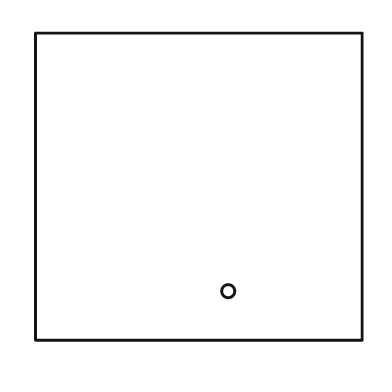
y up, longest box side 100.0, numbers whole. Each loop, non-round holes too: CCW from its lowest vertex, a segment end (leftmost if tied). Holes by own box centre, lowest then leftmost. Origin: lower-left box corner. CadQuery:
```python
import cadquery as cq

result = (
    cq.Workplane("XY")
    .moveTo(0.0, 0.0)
    .lineTo(100.0, 0.0)
    .lineTo(100.0, 94.0)
    .lineTo(0.0, 94.0)
    .close()
    .moveTo(59.0, 15.0)
    .circle(2.0)
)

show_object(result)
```